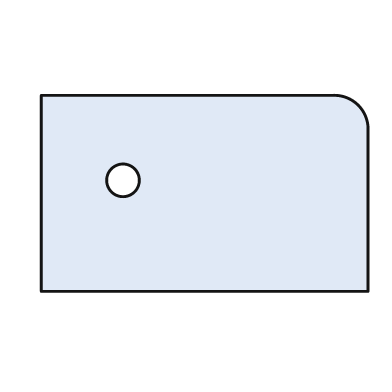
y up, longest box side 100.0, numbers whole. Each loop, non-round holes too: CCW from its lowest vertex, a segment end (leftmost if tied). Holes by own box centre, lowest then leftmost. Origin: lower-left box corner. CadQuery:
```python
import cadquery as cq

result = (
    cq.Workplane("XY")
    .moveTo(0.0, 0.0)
    .lineTo(100.0, 0.0)
    .lineTo(100.0, 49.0)
    .threePointArc((97.0, 57.0), (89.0, 60.0))
    .lineTo(0.0, 60.0)
    .close()
    .moveTo(25.0, 34.0)
    .circle(5.0)
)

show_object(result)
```